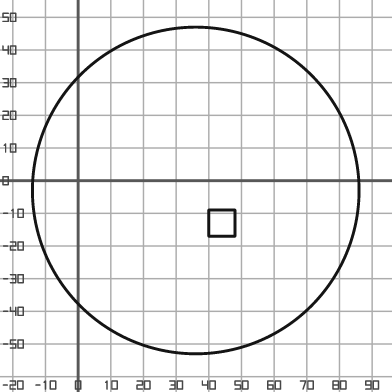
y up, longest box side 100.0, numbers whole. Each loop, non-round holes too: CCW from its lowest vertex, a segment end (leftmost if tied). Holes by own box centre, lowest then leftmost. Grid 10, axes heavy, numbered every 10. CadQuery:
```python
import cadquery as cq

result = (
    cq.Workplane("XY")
    .moveTo(36.0, -3.0)
    .circle(50.0)
    .moveTo(40.0, -17.0)
    .lineTo(48.0, -17.0)
    .lineTo(48.0, -9.0)
    .lineTo(40.0, -9.0)
    .close()
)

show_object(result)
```